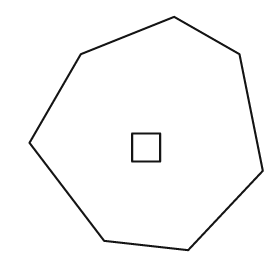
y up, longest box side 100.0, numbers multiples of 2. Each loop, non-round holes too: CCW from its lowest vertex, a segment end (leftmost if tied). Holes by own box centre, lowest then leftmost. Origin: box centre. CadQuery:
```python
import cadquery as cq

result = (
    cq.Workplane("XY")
    .moveTo(18.0, -50.0)
    .lineTo(50.0, -16.0)
    .lineTo(40.0, 34.0)
    .lineTo(12.0, 50.0)
    .lineTo(-28.0, 34.0)
    .lineTo(-50.0, -4.0)
    .lineTo(-18.0, -46.0)
    .close()
    .moveTo(-6.0, -12.0)
    .lineTo(6.0, -12.0)
    .lineTo(6.0, 0.0)
    .lineTo(-6.0, 0.0)
    .close()
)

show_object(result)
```